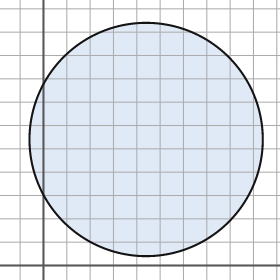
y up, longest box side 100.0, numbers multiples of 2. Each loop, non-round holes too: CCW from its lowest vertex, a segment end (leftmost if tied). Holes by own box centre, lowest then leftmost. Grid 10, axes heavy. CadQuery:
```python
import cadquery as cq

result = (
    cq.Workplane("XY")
    .moveTo(44.0, 54.0)
    .circle(50.0)
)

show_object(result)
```